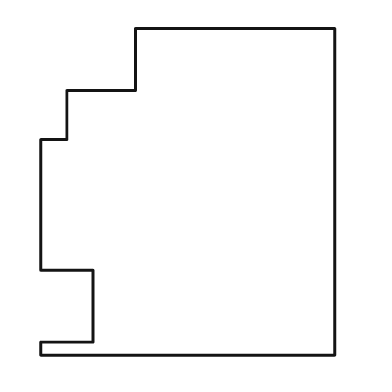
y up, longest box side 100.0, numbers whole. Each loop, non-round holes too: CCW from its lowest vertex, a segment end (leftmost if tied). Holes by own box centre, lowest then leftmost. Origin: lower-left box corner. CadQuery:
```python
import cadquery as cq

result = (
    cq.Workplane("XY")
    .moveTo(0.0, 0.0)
    .lineTo(90.0, 0.0)
    .lineTo(90.0, 100.0)
    .lineTo(29.0, 100.0)
    .lineTo(29.0, 81.0)
    .lineTo(8.0, 81.0)
    .lineTo(8.0, 66.0)
    .lineTo(0.0, 66.0)
    .lineTo(0.0, 26.0)
    .lineTo(16.0, 26.0)
    .lineTo(16.0, 4.0)
    .lineTo(0.0, 4.0)
    .close()
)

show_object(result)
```